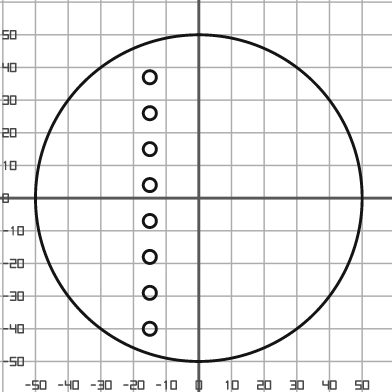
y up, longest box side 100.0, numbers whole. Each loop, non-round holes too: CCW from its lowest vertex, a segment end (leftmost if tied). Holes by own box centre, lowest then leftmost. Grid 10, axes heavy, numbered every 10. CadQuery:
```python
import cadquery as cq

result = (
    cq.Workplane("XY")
    .moveTo(0.0, 0.0)
    .circle(50.0)
    .moveTo(-15.0, -40.0)
    .circle(2.0)
    .moveTo(-15.0, -29.0)
    .circle(2.0)
    .moveTo(-15.0, -18.0)
    .circle(2.0)
    .moveTo(-15.0, -7.0)
    .circle(2.0)
    .moveTo(-15.0, 4.0)
    .circle(2.0)
    .moveTo(-15.0, 15.0)
    .circle(2.0)
    .moveTo(-15.0, 26.0)
    .circle(2.0)
    .moveTo(-15.0, 37.0)
    .circle(2.0)
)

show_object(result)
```